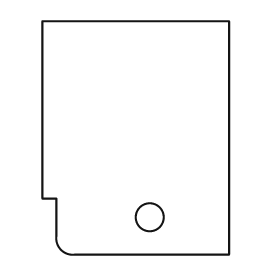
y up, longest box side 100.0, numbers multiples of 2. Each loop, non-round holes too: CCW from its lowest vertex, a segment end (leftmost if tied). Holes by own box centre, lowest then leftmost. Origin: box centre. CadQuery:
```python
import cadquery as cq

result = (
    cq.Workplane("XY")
    .moveTo(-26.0, -50.0)
    .lineTo(40.0, -50.0)
    .lineTo(40.0, 50.0)
    .lineTo(-40.0, 50.0)
    .lineTo(-40.0, -26.0)
    .lineTo(-34.0, -26.0)
    .lineTo(-34.0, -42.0)
    .threePointArc((-32.0, -48.0), (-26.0, -50.0))
    .close()
    .moveTo(6.0, -34.0)
    .circle(6.0)
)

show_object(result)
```